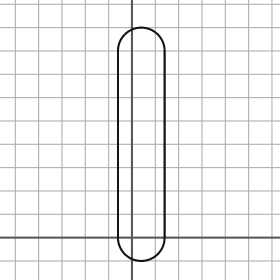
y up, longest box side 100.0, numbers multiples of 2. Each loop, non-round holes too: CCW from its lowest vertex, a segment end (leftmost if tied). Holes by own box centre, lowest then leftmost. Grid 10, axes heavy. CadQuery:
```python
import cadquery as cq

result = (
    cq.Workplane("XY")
    .moveTo(-6.0, 0.0)
    .threePointArc((4.0, -10.0), (14.0, 0.0))
    .lineTo(14.0, 80.0)
    .threePointArc((4.0, 90.0), (-6.0, 80.0))
    .close()
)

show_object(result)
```